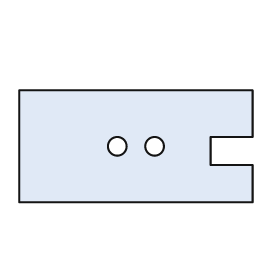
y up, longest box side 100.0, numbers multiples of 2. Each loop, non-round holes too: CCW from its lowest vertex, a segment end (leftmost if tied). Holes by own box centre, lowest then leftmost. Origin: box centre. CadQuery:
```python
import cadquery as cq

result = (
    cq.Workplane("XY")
    .moveTo(-50.0, -24.0)
    .lineTo(50.0, -24.0)
    .lineTo(50.0, -8.0)
    .lineTo(32.0, -8.0)
    .lineTo(32.0, 4.0)
    .lineTo(50.0, 4.0)
    .lineTo(50.0, 24.0)
    .lineTo(-50.0, 24.0)
    .close()
    .moveTo(-8.0, 0.0)
    .circle(4.0)
    .moveTo(8.0, 0.0)
    .circle(4.0)
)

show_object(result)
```